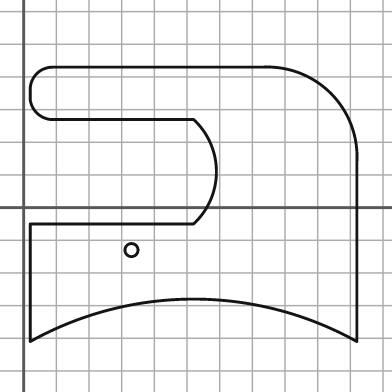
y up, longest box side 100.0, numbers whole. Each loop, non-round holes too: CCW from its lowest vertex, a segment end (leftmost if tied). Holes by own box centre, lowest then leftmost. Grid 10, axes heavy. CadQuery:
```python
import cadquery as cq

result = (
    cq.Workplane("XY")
    .moveTo(2.0, -41.0)
    .threePointArc((52.0, -28.0), (102.0, -41.0))
    .lineTo(102.0, 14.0)
    .threePointArc((94.0, 35.0), (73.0, 43.0))
    .lineTo(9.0, 43.0)
    .threePointArc((4.0, 41.0), (2.0, 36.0))
    .lineTo(2.0, 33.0)
    .threePointArc((4.0, 29.0), (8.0, 27.0))
    .lineTo(52.0, 27.0)
    .threePointArc((59.0, 11.0), (52.0, -5.0))
    .lineTo(2.0, -5.0)
    .close()
    .moveTo(33.0, -13.0)
    .circle(2.0)
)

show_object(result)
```